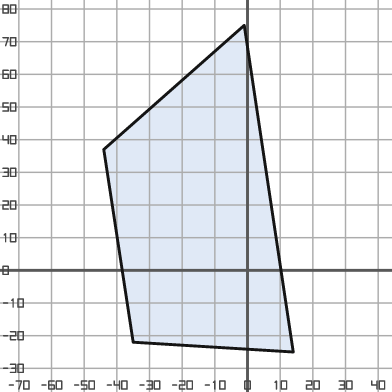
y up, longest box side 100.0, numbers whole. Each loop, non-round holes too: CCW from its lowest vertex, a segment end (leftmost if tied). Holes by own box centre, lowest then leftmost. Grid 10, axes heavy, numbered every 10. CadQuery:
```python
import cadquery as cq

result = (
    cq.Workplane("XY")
    .moveTo(14.0, -25.0)
    .lineTo(-1.0, 75.0)
    .lineTo(-44.0, 37.0)
    .lineTo(-35.0, -22.0)
    .close()
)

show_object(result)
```